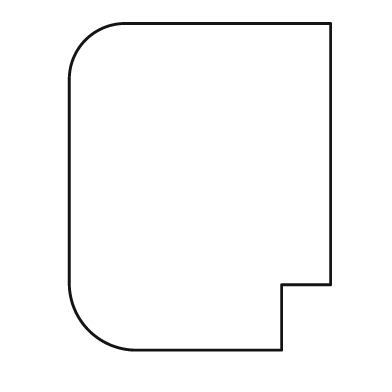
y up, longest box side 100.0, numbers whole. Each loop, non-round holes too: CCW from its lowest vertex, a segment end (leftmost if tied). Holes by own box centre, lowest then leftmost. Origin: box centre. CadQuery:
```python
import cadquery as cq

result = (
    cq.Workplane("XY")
    .moveTo(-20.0, -50.0)
    .lineTo(25.0, -50.0)
    .lineTo(25.0, -30.0)
    .lineTo(40.0, -30.0)
    .lineTo(40.0, 50.0)
    .lineTo(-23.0, 50.0)
    .threePointArc((-35.0, 45.0), (-40.0, 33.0))
    .lineTo(-40.0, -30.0)
    .threePointArc((-34.0, -44.0), (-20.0, -50.0))
    .close()
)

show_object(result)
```